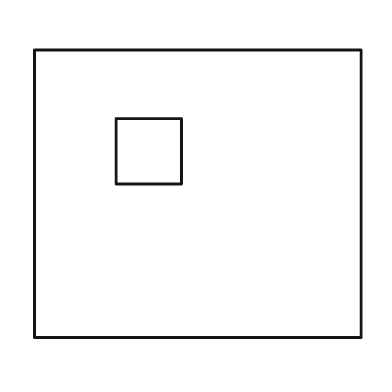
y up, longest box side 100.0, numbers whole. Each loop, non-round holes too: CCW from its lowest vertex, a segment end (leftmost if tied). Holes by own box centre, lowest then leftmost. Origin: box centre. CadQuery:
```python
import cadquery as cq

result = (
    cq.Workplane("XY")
    .moveTo(-50.0, -44.0)
    .lineTo(50.0, -44.0)
    .lineTo(50.0, 44.0)
    .lineTo(-50.0, 44.0)
    .close()
    .moveTo(-25.0, 3.0)
    .lineTo(-5.0, 3.0)
    .lineTo(-5.0, 23.0)
    .lineTo(-25.0, 23.0)
    .close()
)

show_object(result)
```